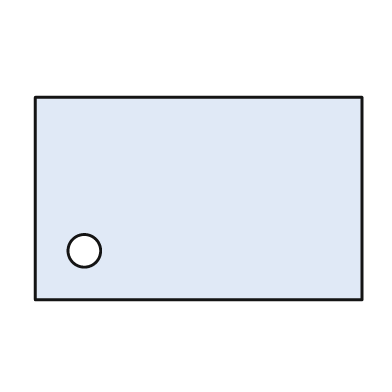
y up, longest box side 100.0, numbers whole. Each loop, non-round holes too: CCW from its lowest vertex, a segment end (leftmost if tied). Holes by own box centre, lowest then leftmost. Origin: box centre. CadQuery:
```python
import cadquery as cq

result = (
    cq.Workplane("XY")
    .moveTo(-50.0, -31.0)
    .lineTo(50.0, -31.0)
    .lineTo(50.0, 31.0)
    .lineTo(-50.0, 31.0)
    .close()
    .moveTo(-35.0, -16.0)
    .circle(5.0)
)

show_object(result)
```